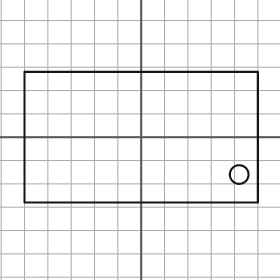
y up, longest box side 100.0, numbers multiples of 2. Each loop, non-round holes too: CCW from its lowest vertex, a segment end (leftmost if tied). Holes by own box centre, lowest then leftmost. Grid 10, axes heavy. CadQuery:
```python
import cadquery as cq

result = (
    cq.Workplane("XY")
    .moveTo(-50.0, -28.0)
    .lineTo(50.0, -28.0)
    .lineTo(50.0, 28.0)
    .lineTo(-50.0, 28.0)
    .close()
    .moveTo(42.0, -16.0)
    .circle(4.0)
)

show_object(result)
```